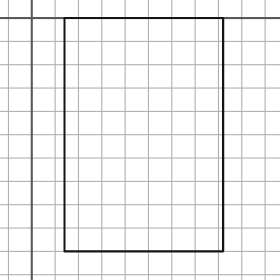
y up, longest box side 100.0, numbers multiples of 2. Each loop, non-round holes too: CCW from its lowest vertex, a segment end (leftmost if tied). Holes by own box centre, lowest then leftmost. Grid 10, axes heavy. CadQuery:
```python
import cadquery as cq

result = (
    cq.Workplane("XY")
    .moveTo(14.0, -100.0)
    .lineTo(82.0, -100.0)
    .lineTo(82.0, 0.0)
    .lineTo(14.0, 0.0)
    .close()
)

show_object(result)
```